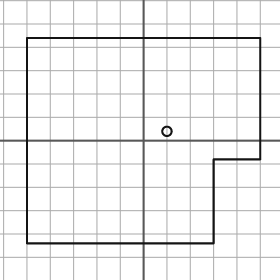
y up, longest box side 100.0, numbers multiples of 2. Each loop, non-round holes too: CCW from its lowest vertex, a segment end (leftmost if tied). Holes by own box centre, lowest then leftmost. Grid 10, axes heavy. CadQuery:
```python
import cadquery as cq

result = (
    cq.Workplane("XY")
    .moveTo(-50.0, -44.0)
    .lineTo(30.0, -44.0)
    .lineTo(30.0, -8.0)
    .lineTo(50.0, -8.0)
    .lineTo(50.0, 44.0)
    .lineTo(-50.0, 44.0)
    .close()
    .moveTo(10.0, 4.0)
    .circle(2.0)
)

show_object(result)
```